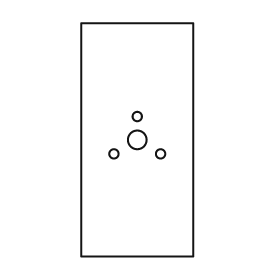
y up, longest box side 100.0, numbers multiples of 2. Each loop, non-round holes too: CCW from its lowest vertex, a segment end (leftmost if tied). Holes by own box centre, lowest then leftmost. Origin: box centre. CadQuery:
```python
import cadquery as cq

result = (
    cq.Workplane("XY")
    .moveTo(-24.0, -50.0)
    .lineTo(24.0, -50.0)
    .lineTo(24.0, 50.0)
    .lineTo(-24.0, 50.0)
    .close()
    .moveTo(-10.0, -6.0)
    .circle(2.0)
    .moveTo(10.0, -6.0)
    .circle(2.0)
    .moveTo(0.0, 0.0)
    .circle(4.0)
    .moveTo(0.0, 10.0)
    .circle(2.0)
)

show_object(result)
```